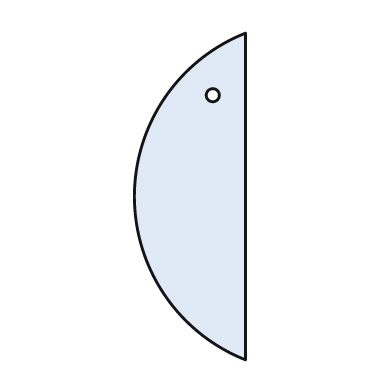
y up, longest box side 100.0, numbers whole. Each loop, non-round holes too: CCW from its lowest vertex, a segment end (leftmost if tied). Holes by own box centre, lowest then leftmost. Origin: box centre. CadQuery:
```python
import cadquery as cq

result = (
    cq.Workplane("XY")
    .moveTo(17.0, -50.0)
    .lineTo(17.0, 50.0)
    .threePointArc((-17.0, 0.0), (17.0, -50.0))
    .close()
    .moveTo(7.0, 31.0)
    .circle(2.0)
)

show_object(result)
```